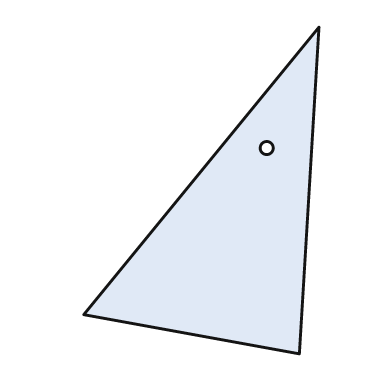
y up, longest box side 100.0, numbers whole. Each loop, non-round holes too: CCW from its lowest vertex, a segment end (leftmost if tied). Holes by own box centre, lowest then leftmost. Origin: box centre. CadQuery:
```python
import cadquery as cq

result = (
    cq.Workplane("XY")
    .moveTo(30.0, -50.0)
    .lineTo(36.0, 50.0)
    .lineTo(-36.0, -38.0)
    .close()
    .moveTo(20.0, 13.0)
    .circle(2.0)
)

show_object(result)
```